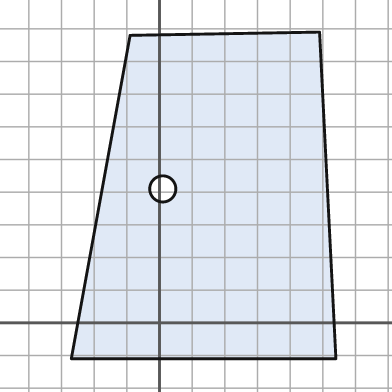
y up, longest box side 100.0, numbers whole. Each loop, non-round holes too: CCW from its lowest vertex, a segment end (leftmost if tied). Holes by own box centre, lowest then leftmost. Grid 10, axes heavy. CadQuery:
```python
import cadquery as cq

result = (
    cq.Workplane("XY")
    .moveTo(-27.0, -11.0)
    .lineTo(54.0, -11.0)
    .lineTo(49.0, 89.0)
    .lineTo(-9.0, 88.0)
    .close()
    .moveTo(1.0, 41.0)
    .circle(4.0)
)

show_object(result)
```